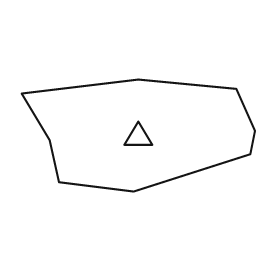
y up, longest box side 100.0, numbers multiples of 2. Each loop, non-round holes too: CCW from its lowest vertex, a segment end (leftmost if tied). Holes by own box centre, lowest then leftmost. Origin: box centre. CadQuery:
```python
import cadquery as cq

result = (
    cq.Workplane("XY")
    .moveTo(-2.0, -24.0)
    .lineTo(48.0, -8.0)
    .lineTo(50.0, 2.0)
    .lineTo(42.0, 20.0)
    .lineTo(0.0, 24.0)
    .lineTo(-50.0, 18.0)
    .lineTo(-38.0, -2.0)
    .lineTo(-34.0, -20.0)
    .close()
    .moveTo(-6.0, -4.0)
    .lineTo(6.0, -4.0)
    .lineTo(0.0, 6.0)
    .close()
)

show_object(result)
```